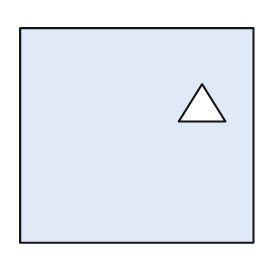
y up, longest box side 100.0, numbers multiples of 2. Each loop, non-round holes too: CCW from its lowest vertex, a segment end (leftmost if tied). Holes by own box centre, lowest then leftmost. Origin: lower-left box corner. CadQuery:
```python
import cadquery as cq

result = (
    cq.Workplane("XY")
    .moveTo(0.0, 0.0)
    .lineTo(100.0, 0.0)
    .lineTo(100.0, 92.0)
    .lineTo(0.0, 92.0)
    .close()
    .moveTo(68.0, 52.0)
    .lineTo(88.0, 52.0)
    .lineTo(78.0, 68.0)
    .close()
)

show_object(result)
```